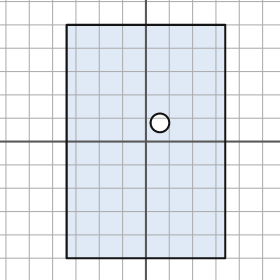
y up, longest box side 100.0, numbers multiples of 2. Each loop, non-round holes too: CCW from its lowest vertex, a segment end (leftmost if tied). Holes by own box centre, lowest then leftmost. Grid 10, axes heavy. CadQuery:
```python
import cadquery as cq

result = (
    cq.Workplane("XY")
    .moveTo(-34.0, -50.0)
    .lineTo(34.0, -50.0)
    .lineTo(34.0, 50.0)
    .lineTo(-34.0, 50.0)
    .close()
    .moveTo(6.0, 8.0)
    .circle(4.0)
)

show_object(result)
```